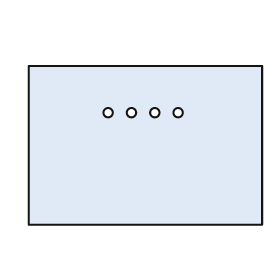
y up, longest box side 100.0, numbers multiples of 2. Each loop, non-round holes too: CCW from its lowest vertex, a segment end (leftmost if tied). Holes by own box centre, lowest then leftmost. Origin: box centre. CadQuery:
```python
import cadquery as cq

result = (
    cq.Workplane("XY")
    .moveTo(-50.0, -34.0)
    .lineTo(50.0, -34.0)
    .lineTo(50.0, 34.0)
    .lineTo(-50.0, 34.0)
    .close()
    .moveTo(-16.0, 14.0)
    .circle(2.0)
    .moveTo(-6.0, 14.0)
    .circle(2.0)
    .moveTo(4.0, 14.0)
    .circle(2.0)
    .moveTo(14.0, 14.0)
    .circle(2.0)
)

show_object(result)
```